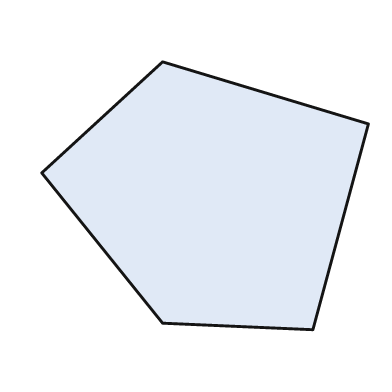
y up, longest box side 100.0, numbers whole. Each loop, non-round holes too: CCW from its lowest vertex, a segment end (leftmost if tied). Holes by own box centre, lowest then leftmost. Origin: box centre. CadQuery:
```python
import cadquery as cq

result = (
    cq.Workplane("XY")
    .moveTo(33.0, -41.0)
    .lineTo(50.0, 22.0)
    .lineTo(-13.0, 41.0)
    .lineTo(-50.0, 7.0)
    .lineTo(-13.0, -39.0)
    .close()
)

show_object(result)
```